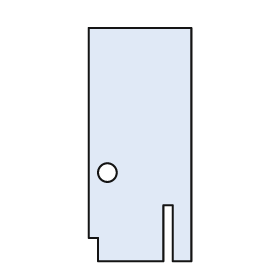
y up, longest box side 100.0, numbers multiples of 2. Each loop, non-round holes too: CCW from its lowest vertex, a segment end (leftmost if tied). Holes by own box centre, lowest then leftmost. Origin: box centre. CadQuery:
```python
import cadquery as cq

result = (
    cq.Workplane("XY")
    .moveTo(-18.0, -50.0)
    .lineTo(10.0, -50.0)
    .lineTo(10.0, -26.0)
    .lineTo(14.0, -26.0)
    .lineTo(14.0, -50.0)
    .lineTo(22.0, -50.0)
    .lineTo(22.0, 50.0)
    .lineTo(-22.0, 50.0)
    .lineTo(-22.0, -40.0)
    .lineTo(-18.0, -40.0)
    .close()
    .moveTo(-14.0, -12.0)
    .circle(4.0)
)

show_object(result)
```